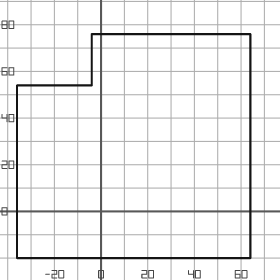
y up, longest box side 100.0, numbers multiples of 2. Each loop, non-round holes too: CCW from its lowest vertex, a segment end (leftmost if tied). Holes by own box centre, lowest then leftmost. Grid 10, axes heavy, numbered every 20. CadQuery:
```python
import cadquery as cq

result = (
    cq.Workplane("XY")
    .moveTo(-36.0, -20.0)
    .lineTo(64.0, -20.0)
    .lineTo(64.0, 76.0)
    .lineTo(-4.0, 76.0)
    .lineTo(-4.0, 54.0)
    .lineTo(-36.0, 54.0)
    .close()
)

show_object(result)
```